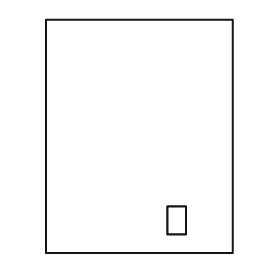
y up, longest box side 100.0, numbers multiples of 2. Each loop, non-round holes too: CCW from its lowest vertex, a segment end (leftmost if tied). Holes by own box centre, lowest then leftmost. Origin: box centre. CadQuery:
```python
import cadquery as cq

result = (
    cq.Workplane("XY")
    .moveTo(-40.0, -50.0)
    .lineTo(40.0, -50.0)
    .lineTo(40.0, 50.0)
    .lineTo(-40.0, 50.0)
    .close()
    .moveTo(12.0, -42.0)
    .lineTo(20.0, -42.0)
    .lineTo(20.0, -30.0)
    .lineTo(12.0, -30.0)
    .close()
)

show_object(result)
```